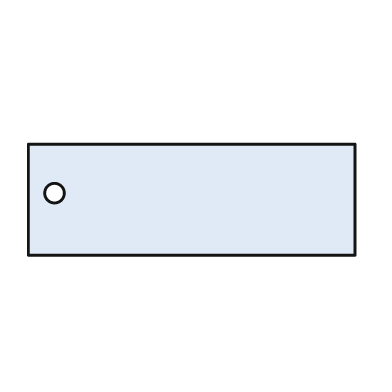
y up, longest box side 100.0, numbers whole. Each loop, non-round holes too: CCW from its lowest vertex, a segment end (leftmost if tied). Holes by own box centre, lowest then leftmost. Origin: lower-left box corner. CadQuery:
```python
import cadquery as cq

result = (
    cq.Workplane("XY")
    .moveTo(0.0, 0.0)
    .lineTo(100.0, 0.0)
    .lineTo(100.0, 34.0)
    .lineTo(0.0, 34.0)
    .close()
    .moveTo(8.0, 19.0)
    .circle(3.0)
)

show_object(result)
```